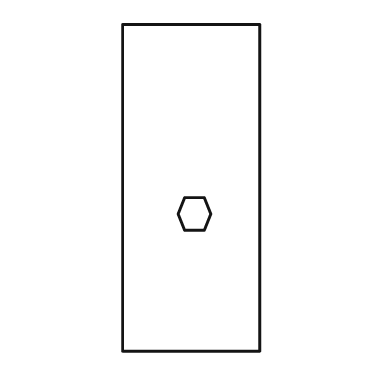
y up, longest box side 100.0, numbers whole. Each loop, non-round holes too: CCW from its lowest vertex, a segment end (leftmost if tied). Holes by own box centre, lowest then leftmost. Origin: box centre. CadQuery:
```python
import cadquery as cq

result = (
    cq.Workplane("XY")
    .moveTo(-21.0, -50.0)
    .lineTo(21.0, -50.0)
    .lineTo(21.0, 50.0)
    .lineTo(-21.0, 50.0)
    .close()
    .moveTo(-2.0, -13.0)
    .lineTo(4.0, -13.0)
    .lineTo(6.0, -8.0)
    .lineTo(4.0, -3.0)
    .lineTo(-2.0, -3.0)
    .lineTo(-4.0, -8.0)
    .close()
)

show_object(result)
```